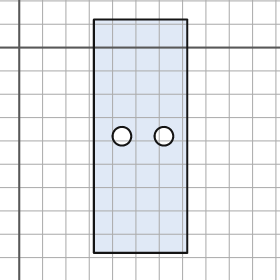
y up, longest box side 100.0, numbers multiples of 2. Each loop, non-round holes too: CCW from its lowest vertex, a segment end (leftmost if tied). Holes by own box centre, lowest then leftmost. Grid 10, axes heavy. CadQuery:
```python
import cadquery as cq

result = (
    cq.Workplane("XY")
    .moveTo(32.0, -88.0)
    .lineTo(72.0, -88.0)
    .lineTo(72.0, 12.0)
    .lineTo(32.0, 12.0)
    .close()
    .moveTo(44.0, -38.0)
    .circle(4.0)
    .moveTo(62.0, -38.0)
    .circle(4.0)
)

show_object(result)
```